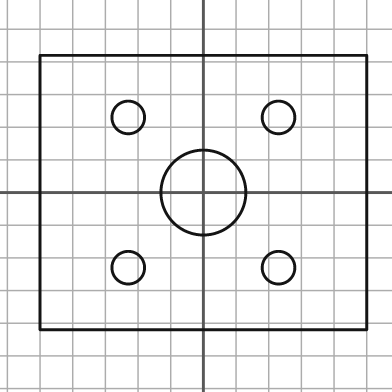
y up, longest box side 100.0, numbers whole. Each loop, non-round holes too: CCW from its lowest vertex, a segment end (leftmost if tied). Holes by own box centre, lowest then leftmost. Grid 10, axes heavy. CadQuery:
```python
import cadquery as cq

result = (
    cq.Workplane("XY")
    .moveTo(-50.0, -42.0)
    .lineTo(50.0, -42.0)
    .lineTo(50.0, 42.0)
    .lineTo(-50.0, 42.0)
    .close()
    .moveTo(-23.0, -23.0)
    .circle(5.0)
    .moveTo(23.0, -23.0)
    .circle(5.0)
    .moveTo(0.0, 0.0)
    .circle(13.0)
    .moveTo(-23.0, 23.0)
    .circle(5.0)
    .moveTo(23.0, 23.0)
    .circle(5.0)
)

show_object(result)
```